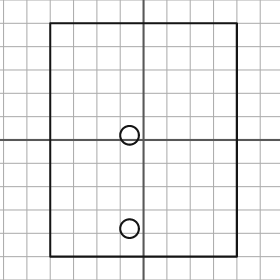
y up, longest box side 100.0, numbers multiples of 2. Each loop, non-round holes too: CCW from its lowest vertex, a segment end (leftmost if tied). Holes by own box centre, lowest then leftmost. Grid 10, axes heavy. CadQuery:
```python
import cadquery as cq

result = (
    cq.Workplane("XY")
    .moveTo(-40.0, -50.0)
    .lineTo(40.0, -50.0)
    .lineTo(40.0, 50.0)
    .lineTo(-40.0, 50.0)
    .close()
    .moveTo(-6.0, -38.0)
    .circle(4.0)
    .moveTo(-6.0, 2.0)
    .circle(4.0)
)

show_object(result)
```